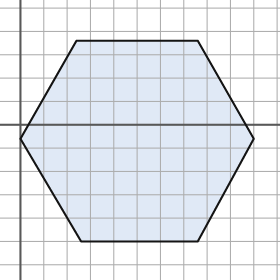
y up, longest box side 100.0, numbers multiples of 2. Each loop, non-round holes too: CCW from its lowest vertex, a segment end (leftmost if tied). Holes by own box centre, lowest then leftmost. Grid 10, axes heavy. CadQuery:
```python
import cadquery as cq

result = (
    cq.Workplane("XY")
    .moveTo(26.0, -50.0)
    .lineTo(76.0, -50.0)
    .lineTo(100.0, -6.0)
    .lineTo(76.0, 36.0)
    .lineTo(24.0, 36.0)
    .lineTo(0.0, -6.0)
    .close()
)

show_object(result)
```